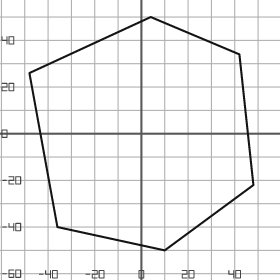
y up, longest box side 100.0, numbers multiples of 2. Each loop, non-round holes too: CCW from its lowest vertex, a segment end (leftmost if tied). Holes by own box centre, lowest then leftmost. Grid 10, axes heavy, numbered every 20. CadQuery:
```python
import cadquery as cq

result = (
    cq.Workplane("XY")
    .moveTo(10.0, -50.0)
    .lineTo(48.0, -22.0)
    .lineTo(42.0, 34.0)
    .lineTo(4.0, 50.0)
    .lineTo(-48.0, 26.0)
    .lineTo(-36.0, -40.0)
    .close()
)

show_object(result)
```